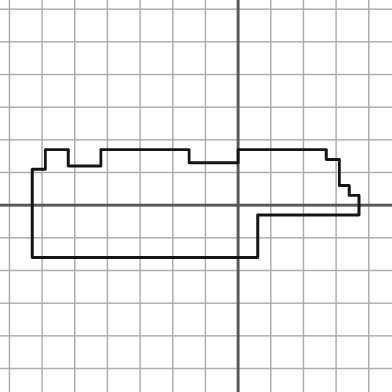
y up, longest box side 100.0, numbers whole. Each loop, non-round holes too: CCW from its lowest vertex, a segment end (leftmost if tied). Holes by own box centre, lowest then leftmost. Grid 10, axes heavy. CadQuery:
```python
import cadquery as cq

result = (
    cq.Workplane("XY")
    .moveTo(-63.0, -16.0)
    .lineTo(6.0, -16.0)
    .lineTo(6.0, -3.0)
    .lineTo(37.0, -3.0)
    .lineTo(37.0, 3.0)
    .lineTo(34.0, 3.0)
    .lineTo(34.0, 6.0)
    .lineTo(31.0, 6.0)
    .lineTo(31.0, 14.0)
    .lineTo(27.0, 14.0)
    .lineTo(27.0, 17.0)
    .lineTo(0.0, 17.0)
    .lineTo(0.0, 13.0)
    .lineTo(-15.0, 13.0)
    .lineTo(-15.0, 17.0)
    .lineTo(-42.0, 17.0)
    .lineTo(-42.0, 12.0)
    .lineTo(-52.0, 12.0)
    .lineTo(-52.0, 17.0)
    .lineTo(-59.0, 17.0)
    .lineTo(-59.0, 11.0)
    .lineTo(-63.0, 11.0)
    .close()
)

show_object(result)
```